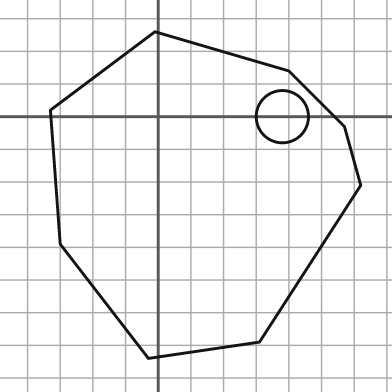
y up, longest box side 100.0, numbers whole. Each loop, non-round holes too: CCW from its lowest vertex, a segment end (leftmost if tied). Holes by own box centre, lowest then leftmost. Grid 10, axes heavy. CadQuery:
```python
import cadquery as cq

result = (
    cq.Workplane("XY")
    .moveTo(-3.0, -74.0)
    .lineTo(31.0, -69.0)
    .lineTo(62.0, -21.0)
    .lineTo(57.0, -3.0)
    .lineTo(40.0, 14.0)
    .lineTo(-1.0, 26.0)
    .lineTo(-33.0, 2.0)
    .lineTo(-30.0, -39.0)
    .close()
    .moveTo(38.0, 0.0)
    .circle(8.0)
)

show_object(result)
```